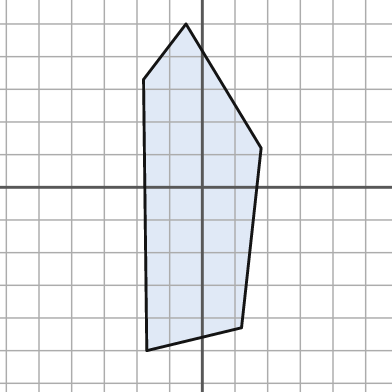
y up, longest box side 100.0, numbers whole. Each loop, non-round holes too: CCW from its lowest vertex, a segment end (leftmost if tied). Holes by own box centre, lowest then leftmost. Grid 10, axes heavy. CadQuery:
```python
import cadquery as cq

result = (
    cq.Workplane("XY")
    .moveTo(-17.0, -50.0)
    .lineTo(12.0, -43.0)
    .lineTo(18.0, 12.0)
    .lineTo(-5.0, 50.0)
    .lineTo(-18.0, 33.0)
    .close()
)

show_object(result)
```